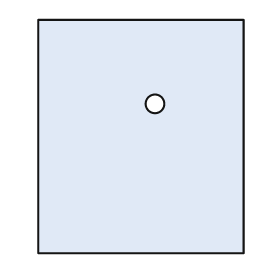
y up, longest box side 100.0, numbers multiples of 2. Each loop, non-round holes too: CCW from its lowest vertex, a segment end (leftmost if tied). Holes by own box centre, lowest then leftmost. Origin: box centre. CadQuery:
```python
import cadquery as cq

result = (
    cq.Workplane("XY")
    .moveTo(-44.0, -50.0)
    .lineTo(44.0, -50.0)
    .lineTo(44.0, 50.0)
    .lineTo(-44.0, 50.0)
    .close()
    .moveTo(6.0, 14.0)
    .circle(4.0)
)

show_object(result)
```